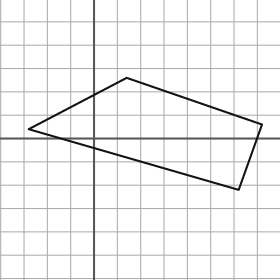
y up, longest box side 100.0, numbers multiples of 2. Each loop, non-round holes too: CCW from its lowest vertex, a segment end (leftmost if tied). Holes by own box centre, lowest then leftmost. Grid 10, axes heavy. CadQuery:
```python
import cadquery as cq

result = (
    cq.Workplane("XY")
    .moveTo(62.0, -22.0)
    .lineTo(72.0, 6.0)
    .lineTo(14.0, 26.0)
    .lineTo(-28.0, 4.0)
    .close()
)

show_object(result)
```